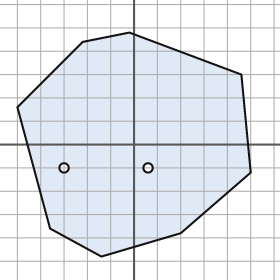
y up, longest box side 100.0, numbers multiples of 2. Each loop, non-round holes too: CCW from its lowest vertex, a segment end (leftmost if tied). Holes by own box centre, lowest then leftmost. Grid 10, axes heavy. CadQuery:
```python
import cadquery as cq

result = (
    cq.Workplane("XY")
    .moveTo(-14.0, -48.0)
    .lineTo(20.0, -38.0)
    .lineTo(50.0, -12.0)
    .lineTo(46.0, 30.0)
    .lineTo(-2.0, 48.0)
    .lineTo(-22.0, 44.0)
    .lineTo(-50.0, 16.0)
    .lineTo(-36.0, -36.0)
    .close()
    .moveTo(-30.0, -10.0)
    .circle(2.0)
    .moveTo(6.0, -10.0)
    .circle(2.0)
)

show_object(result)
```